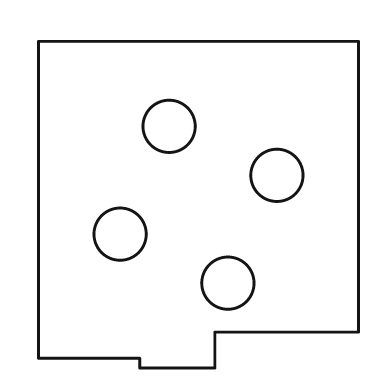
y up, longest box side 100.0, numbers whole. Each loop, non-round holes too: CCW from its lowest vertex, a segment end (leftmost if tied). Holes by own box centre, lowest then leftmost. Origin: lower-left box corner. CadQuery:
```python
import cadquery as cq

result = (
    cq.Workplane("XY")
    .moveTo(31.0, 0.0)
    .lineTo(54.0, 0.0)
    .lineTo(54.0, 11.0)
    .lineTo(98.0, 11.0)
    .lineTo(98.0, 100.0)
    .lineTo(0.0, 100.0)
    .lineTo(0.0, 3.0)
    .lineTo(31.0, 3.0)
    .close()
    .moveTo(58.0, 26.0)
    .circle(8.0)
    .moveTo(25.0, 41.0)
    .circle(8.0)
    .moveTo(73.0, 59.0)
    .circle(8.0)
    .moveTo(40.0, 74.0)
    .circle(8.0)
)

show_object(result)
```